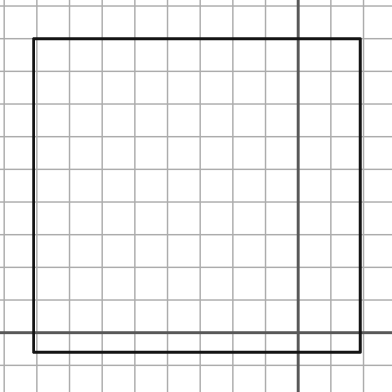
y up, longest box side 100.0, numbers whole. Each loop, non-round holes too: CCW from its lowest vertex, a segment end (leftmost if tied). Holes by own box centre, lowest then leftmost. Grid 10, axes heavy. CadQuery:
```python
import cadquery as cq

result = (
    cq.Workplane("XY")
    .moveTo(-81.0, -6.0)
    .lineTo(19.0, -6.0)
    .lineTo(19.0, 90.0)
    .lineTo(-81.0, 90.0)
    .close()
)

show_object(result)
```